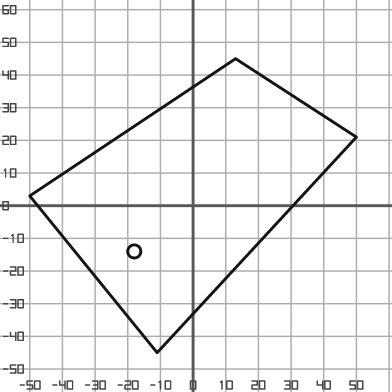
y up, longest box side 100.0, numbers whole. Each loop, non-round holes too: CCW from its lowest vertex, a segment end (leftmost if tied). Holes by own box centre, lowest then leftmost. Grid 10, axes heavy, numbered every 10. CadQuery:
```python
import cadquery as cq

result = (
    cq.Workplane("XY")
    .moveTo(-11.0, -45.0)
    .lineTo(50.0, 21.0)
    .lineTo(13.0, 45.0)
    .lineTo(-50.0, 3.0)
    .close()
    .moveTo(-18.0, -14.0)
    .circle(2.0)
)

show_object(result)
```